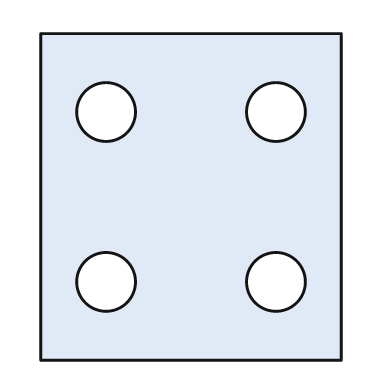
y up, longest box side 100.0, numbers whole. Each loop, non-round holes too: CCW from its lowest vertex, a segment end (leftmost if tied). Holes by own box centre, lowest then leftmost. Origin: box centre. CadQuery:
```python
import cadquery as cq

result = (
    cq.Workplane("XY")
    .moveTo(-46.0, -50.0)
    .lineTo(46.0, -50.0)
    .lineTo(46.0, 50.0)
    .lineTo(-46.0, 50.0)
    .close()
    .moveTo(-26.0, -26.0)
    .circle(9.0)
    .moveTo(26.0, -26.0)
    .circle(9.0)
    .moveTo(-26.0, 26.0)
    .circle(9.0)
    .moveTo(26.0, 26.0)
    .circle(9.0)
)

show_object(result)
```